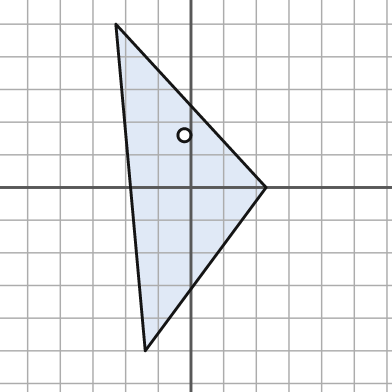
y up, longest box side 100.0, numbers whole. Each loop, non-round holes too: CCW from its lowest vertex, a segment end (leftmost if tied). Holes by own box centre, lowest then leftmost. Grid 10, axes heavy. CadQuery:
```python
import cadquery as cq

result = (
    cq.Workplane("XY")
    .moveTo(-14.0, -50.0)
    .lineTo(23.0, 0.0)
    .lineTo(-23.0, 50.0)
    .close()
    .moveTo(-2.0, 16.0)
    .circle(2.0)
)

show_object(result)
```